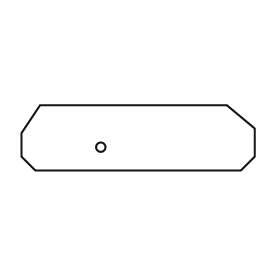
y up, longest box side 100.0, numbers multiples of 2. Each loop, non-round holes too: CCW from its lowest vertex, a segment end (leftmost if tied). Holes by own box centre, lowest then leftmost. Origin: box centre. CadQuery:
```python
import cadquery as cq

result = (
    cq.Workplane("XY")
    .moveTo(-44.0, -14.0)
    .lineTo(44.0, -14.0)
    .lineTo(50.0, -8.0)
    .lineTo(50.0, 4.0)
    .lineTo(38.0, 14.0)
    .lineTo(-42.0, 14.0)
    .lineTo(-50.0, 2.0)
    .lineTo(-50.0, -8.0)
    .close()
    .moveTo(-16.0, -4.0)
    .circle(2.0)
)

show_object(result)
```